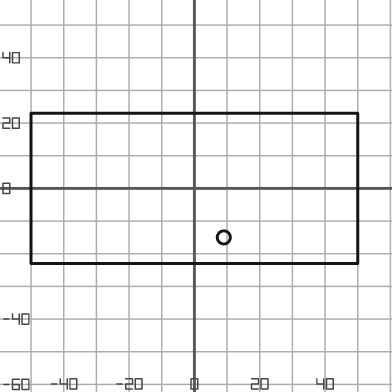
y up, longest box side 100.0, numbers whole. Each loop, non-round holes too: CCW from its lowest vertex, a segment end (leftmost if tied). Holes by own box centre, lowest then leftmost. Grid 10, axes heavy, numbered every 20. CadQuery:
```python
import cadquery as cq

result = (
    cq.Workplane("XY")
    .moveTo(-50.0, -23.0)
    .lineTo(50.0, -23.0)
    .lineTo(50.0, 23.0)
    .lineTo(-50.0, 23.0)
    .close()
    .moveTo(9.0, -15.0)
    .circle(2.0)
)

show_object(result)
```